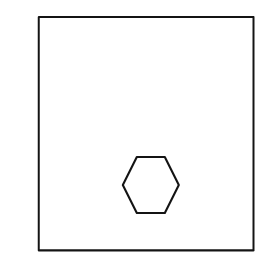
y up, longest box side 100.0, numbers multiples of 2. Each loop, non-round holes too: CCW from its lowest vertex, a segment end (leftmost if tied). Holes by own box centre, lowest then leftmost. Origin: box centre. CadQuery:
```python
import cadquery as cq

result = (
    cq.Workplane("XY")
    .moveTo(-46.0, -50.0)
    .lineTo(46.0, -50.0)
    .lineTo(46.0, 50.0)
    .lineTo(-46.0, 50.0)
    .close()
    .moveTo(-4.0, -34.0)
    .lineTo(8.0, -34.0)
    .lineTo(14.0, -22.0)
    .lineTo(8.0, -10.0)
    .lineTo(-4.0, -10.0)
    .lineTo(-10.0, -22.0)
    .close()
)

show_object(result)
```